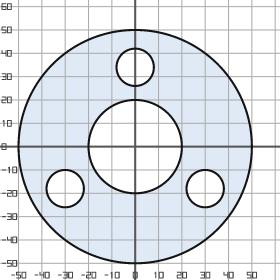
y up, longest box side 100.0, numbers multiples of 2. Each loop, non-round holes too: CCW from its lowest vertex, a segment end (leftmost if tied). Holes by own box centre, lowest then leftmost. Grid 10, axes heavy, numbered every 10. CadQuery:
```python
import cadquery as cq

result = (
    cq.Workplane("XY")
    .moveTo(0.0, 0.0)
    .circle(50.0)
    .moveTo(-30.0, -18.0)
    .circle(8.0)
    .moveTo(30.0, -18.0)
    .circle(8.0)
    .moveTo(0.0, 0.0)
    .circle(20.0)
    .moveTo(0.0, 34.0)
    .circle(8.0)
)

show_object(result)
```